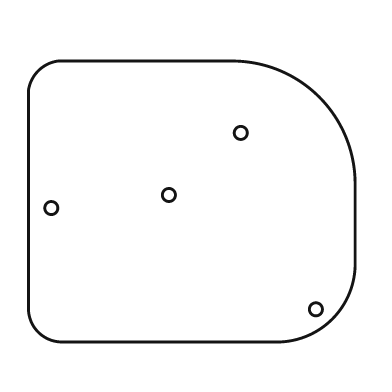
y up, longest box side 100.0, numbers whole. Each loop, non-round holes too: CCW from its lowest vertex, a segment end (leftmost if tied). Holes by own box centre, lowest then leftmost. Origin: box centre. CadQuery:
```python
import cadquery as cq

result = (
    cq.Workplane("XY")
    .moveTo(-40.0, -43.0)
    .lineTo(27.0, -43.0)
    .threePointArc((43.0, -36.0), (50.0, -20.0))
    .lineTo(50.0, 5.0)
    .threePointArc((39.0, 32.0), (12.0, 43.0))
    .lineTo(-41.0, 43.0)
    .threePointArc((-47.0, 40.0), (-50.0, 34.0))
    .lineTo(-50.0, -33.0)
    .threePointArc((-47.0, -40.0), (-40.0, -43.0))
    .close()
    .moveTo(38.0, -33.0)
    .circle(2.0)
    .moveTo(-43.0, -2.0)
    .circle(2.0)
    .moveTo(-7.0, 2.0)
    .circle(2.0)
    .moveTo(15.0, 21.0)
    .circle(2.0)
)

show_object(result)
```